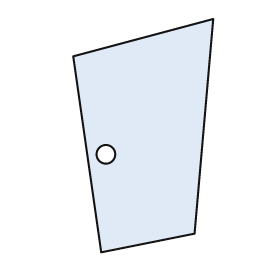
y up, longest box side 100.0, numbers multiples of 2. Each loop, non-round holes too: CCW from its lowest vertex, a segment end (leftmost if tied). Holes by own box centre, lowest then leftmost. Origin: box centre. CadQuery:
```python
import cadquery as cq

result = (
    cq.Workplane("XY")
    .moveTo(-18.0, -50.0)
    .lineTo(22.0, -42.0)
    .lineTo(30.0, 50.0)
    .lineTo(-30.0, 34.0)
    .close()
    .moveTo(-16.0, -8.0)
    .circle(4.0)
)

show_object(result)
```